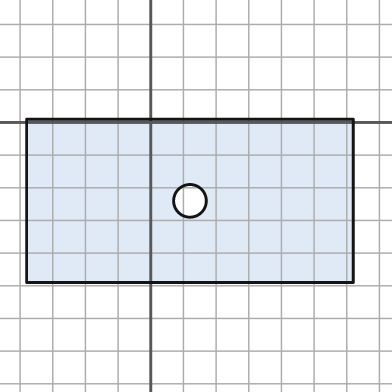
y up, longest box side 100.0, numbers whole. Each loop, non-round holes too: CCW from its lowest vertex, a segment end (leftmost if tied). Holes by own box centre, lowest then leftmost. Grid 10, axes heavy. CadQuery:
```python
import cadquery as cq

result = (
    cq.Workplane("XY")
    .moveTo(-38.0, -49.0)
    .lineTo(62.0, -49.0)
    .lineTo(62.0, 1.0)
    .lineTo(-38.0, 1.0)
    .close()
    .moveTo(12.0, -24.0)
    .circle(5.0)
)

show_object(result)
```